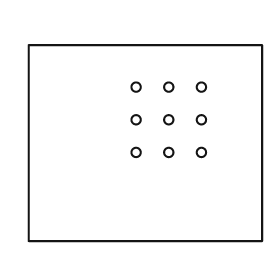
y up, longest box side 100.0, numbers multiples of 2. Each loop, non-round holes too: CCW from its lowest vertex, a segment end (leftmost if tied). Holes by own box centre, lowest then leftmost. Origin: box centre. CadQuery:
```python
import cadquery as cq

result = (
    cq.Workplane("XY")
    .moveTo(-50.0, -42.0)
    .lineTo(50.0, -42.0)
    .lineTo(50.0, 42.0)
    .lineTo(-50.0, 42.0)
    .close()
    .moveTo(-4.0, -4.0)
    .circle(2.0)
    .moveTo(10.0, -4.0)
    .circle(2.0)
    .moveTo(24.0, -4.0)
    .circle(2.0)
    .moveTo(-4.0, 10.0)
    .circle(2.0)
    .moveTo(10.0, 10.0)
    .circle(2.0)
    .moveTo(24.0, 10.0)
    .circle(2.0)
    .moveTo(-4.0, 24.0)
    .circle(2.0)
    .moveTo(10.0, 24.0)
    .circle(2.0)
    .moveTo(24.0, 24.0)
    .circle(2.0)
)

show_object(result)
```